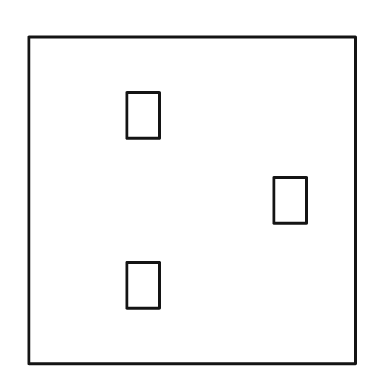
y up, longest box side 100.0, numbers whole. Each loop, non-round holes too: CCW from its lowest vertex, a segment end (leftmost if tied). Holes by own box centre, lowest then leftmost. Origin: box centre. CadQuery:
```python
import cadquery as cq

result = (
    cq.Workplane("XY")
    .moveTo(-50.0, -50.0)
    .lineTo(50.0, -50.0)
    .lineTo(50.0, 50.0)
    .lineTo(-50.0, 50.0)
    .close()
    .moveTo(-20.0, -33.0)
    .lineTo(-10.0, -33.0)
    .lineTo(-10.0, -19.0)
    .lineTo(-20.0, -19.0)
    .close()
    .moveTo(25.0, -7.0)
    .lineTo(35.0, -7.0)
    .lineTo(35.0, 7.0)
    .lineTo(25.0, 7.0)
    .close()
    .moveTo(-20.0, 19.0)
    .lineTo(-10.0, 19.0)
    .lineTo(-10.0, 33.0)
    .lineTo(-20.0, 33.0)
    .close()
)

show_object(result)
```